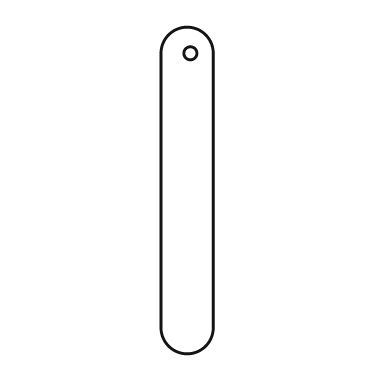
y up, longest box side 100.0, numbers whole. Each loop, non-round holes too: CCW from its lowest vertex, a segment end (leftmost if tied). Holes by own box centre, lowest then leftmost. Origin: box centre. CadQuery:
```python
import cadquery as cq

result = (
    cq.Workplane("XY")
    .moveTo(-8.0, -42.0)
    .threePointArc((0.0, -50.0), (8.0, -42.0))
    .lineTo(8.0, 42.0)
    .threePointArc((0.0, 50.0), (-8.0, 42.0))
    .close()
    .moveTo(1.0, 42.0)
    .circle(2.0)
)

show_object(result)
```